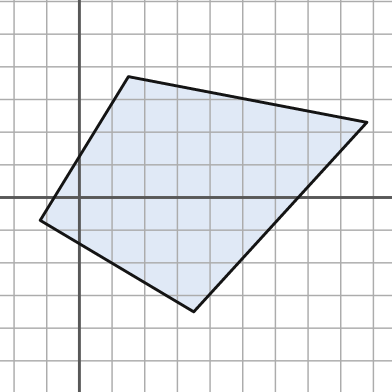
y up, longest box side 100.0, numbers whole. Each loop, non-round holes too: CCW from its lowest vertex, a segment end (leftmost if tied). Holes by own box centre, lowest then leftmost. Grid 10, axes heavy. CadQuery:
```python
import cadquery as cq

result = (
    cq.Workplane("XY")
    .moveTo(35.0, -35.0)
    .lineTo(88.0, 23.0)
    .lineTo(15.0, 37.0)
    .lineTo(-12.0, -7.0)
    .close()
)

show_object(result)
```